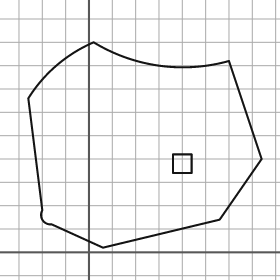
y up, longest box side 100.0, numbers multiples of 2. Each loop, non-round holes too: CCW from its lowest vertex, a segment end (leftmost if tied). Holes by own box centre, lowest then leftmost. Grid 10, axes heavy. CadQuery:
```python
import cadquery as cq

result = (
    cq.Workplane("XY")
    .moveTo(6.0, 2.0)
    .lineTo(56.0, 14.0)
    .lineTo(74.0, 40.0)
    .lineTo(60.0, 82.0)
    .threePointArc((30.0, 80.0), (2.0, 90.0))
    .threePointArc((-14.0, 80.0), (-26.0, 66.0))
    .lineTo(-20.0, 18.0)
    .threePointArc((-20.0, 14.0), (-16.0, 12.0))
    .close()
    .moveTo(36.0, 34.0)
    .lineTo(44.0, 34.0)
    .lineTo(44.0, 42.0)
    .lineTo(36.0, 42.0)
    .close()
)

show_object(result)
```